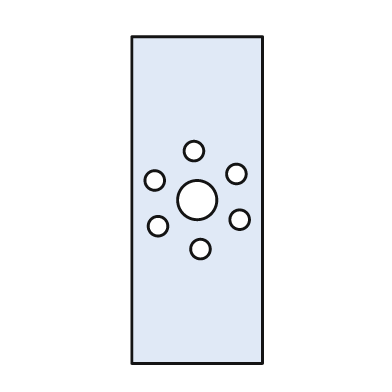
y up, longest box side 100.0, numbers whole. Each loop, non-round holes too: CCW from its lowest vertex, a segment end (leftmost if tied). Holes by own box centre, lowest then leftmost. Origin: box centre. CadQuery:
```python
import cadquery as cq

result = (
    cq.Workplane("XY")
    .moveTo(-20.0, -50.0)
    .lineTo(20.0, -50.0)
    .lineTo(20.0, 50.0)
    .lineTo(-20.0, 50.0)
    .close()
    .moveTo(1.0, -15.0)
    .circle(3.0)
    .moveTo(-12.0, -8.0)
    .circle(3.0)
    .moveTo(13.0, -6.0)
    .circle(3.0)
    .moveTo(0.0, 0.0)
    .circle(6.0)
    .moveTo(-13.0, 6.0)
    .circle(3.0)
    .moveTo(12.0, 8.0)
    .circle(3.0)
    .moveTo(-1.0, 15.0)
    .circle(3.0)
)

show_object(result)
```